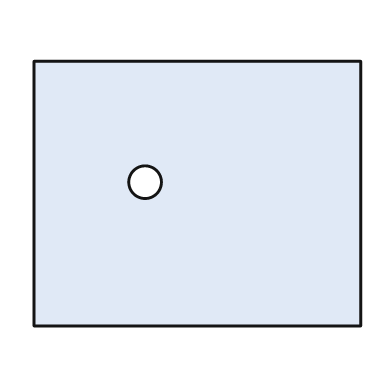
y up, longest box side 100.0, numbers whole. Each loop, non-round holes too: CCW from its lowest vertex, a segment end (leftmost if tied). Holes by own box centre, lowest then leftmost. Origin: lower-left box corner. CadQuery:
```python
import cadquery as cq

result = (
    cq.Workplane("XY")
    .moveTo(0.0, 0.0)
    .lineTo(100.0, 0.0)
    .lineTo(100.0, 81.0)
    .lineTo(0.0, 81.0)
    .close()
    .moveTo(34.0, 44.0)
    .circle(5.0)
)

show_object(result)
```